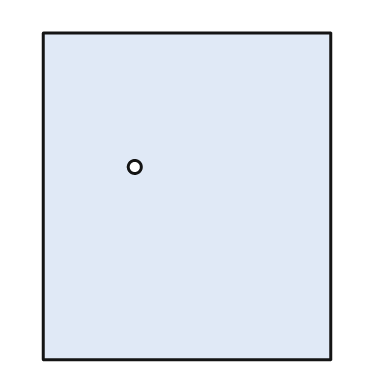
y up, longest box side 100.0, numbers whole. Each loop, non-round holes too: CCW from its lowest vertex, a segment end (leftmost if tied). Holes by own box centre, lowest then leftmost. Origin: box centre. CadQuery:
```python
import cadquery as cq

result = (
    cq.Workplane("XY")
    .moveTo(-44.0, -50.0)
    .lineTo(44.0, -50.0)
    .lineTo(44.0, 50.0)
    .lineTo(-44.0, 50.0)
    .close()
    .moveTo(-16.0, 9.0)
    .circle(2.0)
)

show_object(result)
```